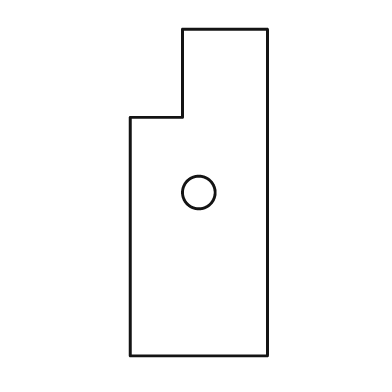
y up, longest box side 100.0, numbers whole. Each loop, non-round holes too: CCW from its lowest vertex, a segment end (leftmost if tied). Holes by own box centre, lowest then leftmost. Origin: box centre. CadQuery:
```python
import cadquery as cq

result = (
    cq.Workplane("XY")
    .moveTo(-21.0, -50.0)
    .lineTo(21.0, -50.0)
    .lineTo(21.0, 50.0)
    .lineTo(-5.0, 50.0)
    .lineTo(-5.0, 23.0)
    .lineTo(-21.0, 23.0)
    .close()
    .moveTo(0.0, 0.0)
    .circle(5.0)
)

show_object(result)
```